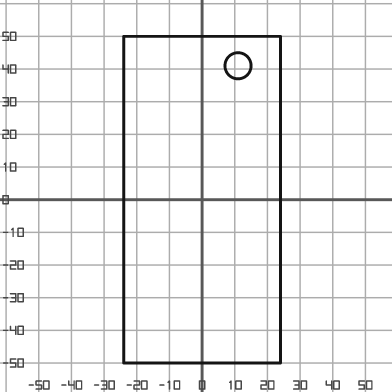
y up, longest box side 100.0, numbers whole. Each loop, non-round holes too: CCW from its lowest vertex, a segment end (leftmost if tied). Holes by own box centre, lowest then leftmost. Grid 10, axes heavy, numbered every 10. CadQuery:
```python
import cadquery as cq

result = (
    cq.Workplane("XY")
    .moveTo(-24.0, -50.0)
    .lineTo(24.0, -50.0)
    .lineTo(24.0, 50.0)
    .lineTo(-24.0, 50.0)
    .close()
    .moveTo(11.0, 41.0)
    .circle(4.0)
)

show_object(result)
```